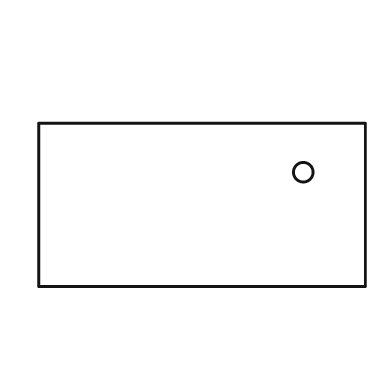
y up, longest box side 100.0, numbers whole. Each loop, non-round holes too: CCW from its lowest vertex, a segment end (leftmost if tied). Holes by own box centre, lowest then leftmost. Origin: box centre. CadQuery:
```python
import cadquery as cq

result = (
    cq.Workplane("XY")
    .moveTo(-50.0, -25.0)
    .lineTo(50.0, -25.0)
    .lineTo(50.0, 25.0)
    .lineTo(-50.0, 25.0)
    .close()
    .moveTo(31.0, 10.0)
    .circle(3.0)
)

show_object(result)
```